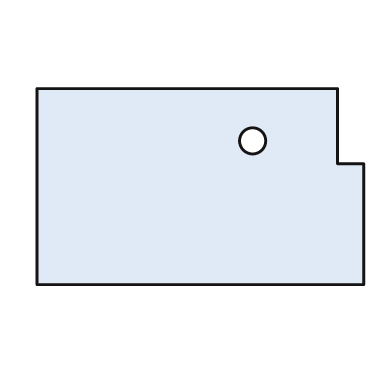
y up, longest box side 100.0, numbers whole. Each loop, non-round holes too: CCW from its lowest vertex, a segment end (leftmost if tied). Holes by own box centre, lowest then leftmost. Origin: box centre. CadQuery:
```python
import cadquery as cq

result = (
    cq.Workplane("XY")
    .moveTo(-50.0, -30.0)
    .lineTo(50.0, -30.0)
    .lineTo(50.0, 7.0)
    .lineTo(42.0, 7.0)
    .lineTo(42.0, 30.0)
    .lineTo(-50.0, 30.0)
    .close()
    .moveTo(16.0, 14.0)
    .circle(4.0)
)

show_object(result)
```